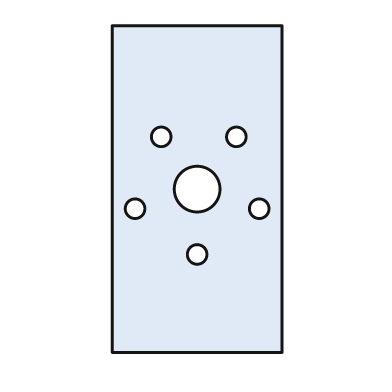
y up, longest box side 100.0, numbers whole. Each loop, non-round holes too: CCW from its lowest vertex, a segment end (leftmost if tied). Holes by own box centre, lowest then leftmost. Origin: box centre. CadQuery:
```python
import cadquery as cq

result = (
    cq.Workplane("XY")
    .moveTo(-26.0, -50.0)
    .lineTo(26.0, -50.0)
    .lineTo(26.0, 50.0)
    .lineTo(-26.0, 50.0)
    .close()
    .moveTo(0.0, -20.0)
    .circle(3.0)
    .moveTo(-19.0, -6.0)
    .circle(3.0)
    .moveTo(19.0, -6.0)
    .circle(3.0)
    .moveTo(0.0, 0.0)
    .circle(7.0)
    .moveTo(-11.0, 16.0)
    .circle(3.0)
    .moveTo(12.0, 16.0)
    .circle(3.0)
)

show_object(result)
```